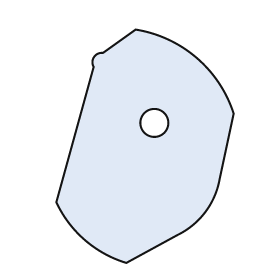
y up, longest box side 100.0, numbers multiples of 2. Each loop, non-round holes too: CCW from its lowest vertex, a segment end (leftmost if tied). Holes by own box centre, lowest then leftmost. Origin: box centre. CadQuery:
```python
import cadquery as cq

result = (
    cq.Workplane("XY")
    .moveTo(-8.0, -50.0)
    .lineTo(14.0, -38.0)
    .threePointArc((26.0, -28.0), (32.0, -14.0))
    .lineTo(38.0, 14.0)
    .threePointArc((22.0, 38.0), (-4.0, 50.0))
    .lineTo(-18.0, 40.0)
    .threePointArc((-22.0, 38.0), (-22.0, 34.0))
    .lineTo(-38.0, -24.0)
    .threePointArc((-26.0, -40.0), (-8.0, -50.0))
    .close()
    .moveTo(4.0, 10.0)
    .circle(6.0)
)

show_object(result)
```